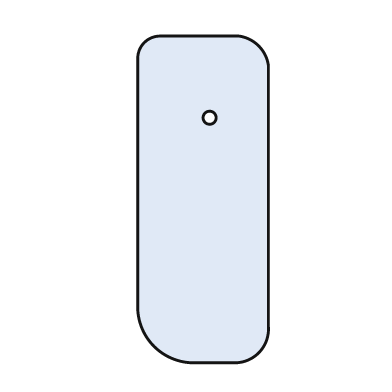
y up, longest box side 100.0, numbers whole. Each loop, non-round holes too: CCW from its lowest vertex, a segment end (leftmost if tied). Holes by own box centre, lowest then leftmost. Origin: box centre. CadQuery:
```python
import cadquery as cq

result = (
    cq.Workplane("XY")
    .moveTo(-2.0, -50.0)
    .lineTo(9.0, -50.0)
    .threePointArc((17.0, -47.0), (20.0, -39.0))
    .lineTo(20.0, 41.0)
    .threePointArc((17.0, 47.0), (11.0, 50.0))
    .lineTo(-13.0, 50.0)
    .threePointArc((-18.0, 48.0), (-20.0, 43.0))
    .lineTo(-20.0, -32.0)
    .threePointArc((-15.0, -45.0), (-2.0, -50.0))
    .close()
    .moveTo(2.0, 25.0)
    .circle(2.0)
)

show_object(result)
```